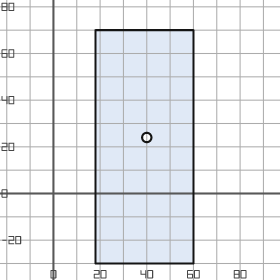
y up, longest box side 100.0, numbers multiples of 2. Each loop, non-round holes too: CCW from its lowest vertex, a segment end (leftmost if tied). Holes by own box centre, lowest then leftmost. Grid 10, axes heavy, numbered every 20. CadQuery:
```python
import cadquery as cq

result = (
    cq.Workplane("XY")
    .moveTo(18.0, -30.0)
    .lineTo(60.0, -30.0)
    .lineTo(60.0, 70.0)
    .lineTo(18.0, 70.0)
    .close()
    .moveTo(40.0, 24.0)
    .circle(2.0)
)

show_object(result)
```